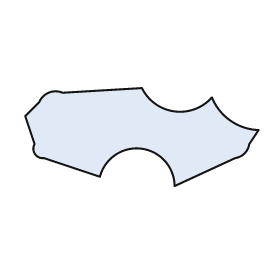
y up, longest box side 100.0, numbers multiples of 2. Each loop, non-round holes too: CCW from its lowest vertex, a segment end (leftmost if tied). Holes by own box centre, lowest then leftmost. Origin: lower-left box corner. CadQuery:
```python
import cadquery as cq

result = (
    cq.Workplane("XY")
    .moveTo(64.0, 0.0)
    .lineTo(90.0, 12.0)
    .threePointArc((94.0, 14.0), (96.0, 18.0))
    .lineTo(100.0, 24.0)
    .threePointArc((88.0, 28.0), (80.0, 38.0))
    .threePointArc((64.0, 32.0), (50.0, 42.0))
    .lineTo(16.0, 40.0)
    .threePointArc((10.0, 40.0), (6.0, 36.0))
    .lineTo(0.0, 30.0)
    .lineTo(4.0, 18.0)
    .threePointArc((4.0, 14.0), (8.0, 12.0))
    .lineTo(32.0, 4.0)
    .threePointArc((50.0, 16.0), (64.0, 0.0))
    .close()
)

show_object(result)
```